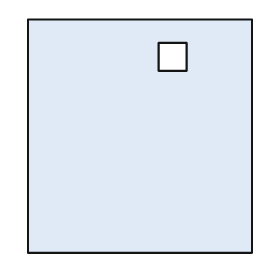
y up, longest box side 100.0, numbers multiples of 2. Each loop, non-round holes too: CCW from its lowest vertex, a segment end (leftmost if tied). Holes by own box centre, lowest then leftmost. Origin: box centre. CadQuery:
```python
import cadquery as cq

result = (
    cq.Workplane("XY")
    .moveTo(-48.0, -50.0)
    .lineTo(48.0, -50.0)
    .lineTo(48.0, 50.0)
    .lineTo(-48.0, 50.0)
    .close()
    .moveTo(8.0, 28.0)
    .lineTo(20.0, 28.0)
    .lineTo(20.0, 40.0)
    .lineTo(8.0, 40.0)
    .close()
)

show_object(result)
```